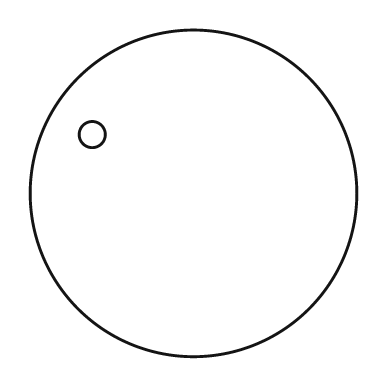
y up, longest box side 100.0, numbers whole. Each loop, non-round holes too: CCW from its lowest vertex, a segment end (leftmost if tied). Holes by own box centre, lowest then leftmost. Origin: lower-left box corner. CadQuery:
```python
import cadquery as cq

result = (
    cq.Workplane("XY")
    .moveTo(50.0, 50.0)
    .circle(50.0)
    .moveTo(19.0, 68.0)
    .circle(4.0)
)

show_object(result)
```